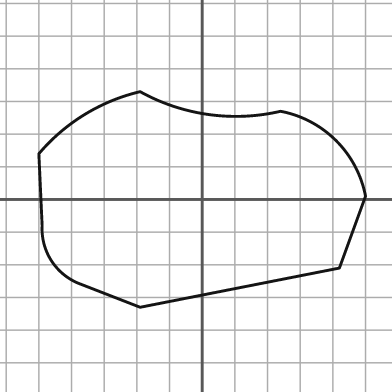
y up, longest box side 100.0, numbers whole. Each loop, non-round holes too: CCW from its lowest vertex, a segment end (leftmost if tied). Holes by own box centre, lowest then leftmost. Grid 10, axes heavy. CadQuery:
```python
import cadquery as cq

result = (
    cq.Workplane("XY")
    .moveTo(-19.0, -33.0)
    .lineTo(42.0, -21.0)
    .lineTo(50.0, 1.0)
    .threePointArc((41.0, 18.0), (24.0, 27.0))
    .threePointArc((2.0, 26.0), (-19.0, 33.0))
    .threePointArc((-36.0, 26.0), (-50.0, 14.0))
    .lineTo(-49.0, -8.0)
    .threePointArc((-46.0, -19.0), (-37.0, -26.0))
    .close()
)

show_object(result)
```